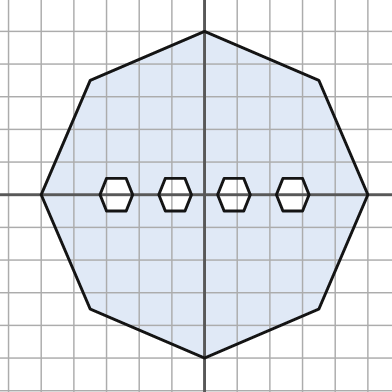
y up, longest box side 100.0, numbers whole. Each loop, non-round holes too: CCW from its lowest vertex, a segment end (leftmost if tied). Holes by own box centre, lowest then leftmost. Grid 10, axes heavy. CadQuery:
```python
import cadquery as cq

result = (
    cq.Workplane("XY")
    .moveTo(0.0, -50.0)
    .lineTo(35.0, -35.0)
    .lineTo(50.0, 0.0)
    .lineTo(35.0, 35.0)
    .lineTo(0.0, 50.0)
    .lineTo(-35.0, 35.0)
    .lineTo(-50.0, 0.0)
    .lineTo(-35.0, -35.0)
    .close()
    .moveTo(-30.0, -5.0)
    .lineTo(-24.0, -5.0)
    .lineTo(-22.0, 0.0)
    .lineTo(-24.0, 5.0)
    .lineTo(-30.0, 5.0)
    .lineTo(-32.0, 0.0)
    .close()
    .moveTo(-12.0, -5.0)
    .lineTo(-6.0, -5.0)
    .lineTo(-4.0, 0.0)
    .lineTo(-6.0, 5.0)
    .lineTo(-12.0, 5.0)
    .lineTo(-14.0, 0.0)
    .close()
    .moveTo(6.0, -5.0)
    .lineTo(12.0, -5.0)
    .lineTo(14.0, 0.0)
    .lineTo(12.0, 5.0)
    .lineTo(6.0, 5.0)
    .lineTo(4.0, 0.0)
    .close()
    .moveTo(24.0, -5.0)
    .lineTo(30.0, -5.0)
    .lineTo(32.0, 0.0)
    .lineTo(30.0, 5.0)
    .lineTo(24.0, 5.0)
    .lineTo(22.0, 0.0)
    .close()
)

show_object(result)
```